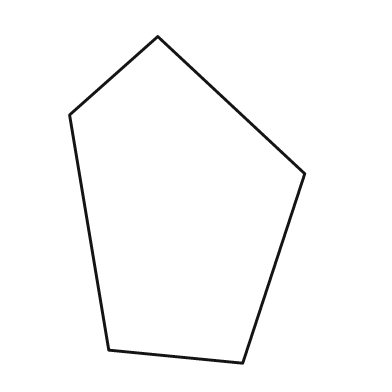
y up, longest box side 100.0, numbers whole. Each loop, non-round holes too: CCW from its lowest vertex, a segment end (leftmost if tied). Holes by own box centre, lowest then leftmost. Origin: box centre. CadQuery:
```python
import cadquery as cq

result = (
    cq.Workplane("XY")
    .moveTo(17.0, -50.0)
    .lineTo(36.0, 8.0)
    .lineTo(-9.0, 50.0)
    .lineTo(-36.0, 26.0)
    .lineTo(-24.0, -46.0)
    .close()
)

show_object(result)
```